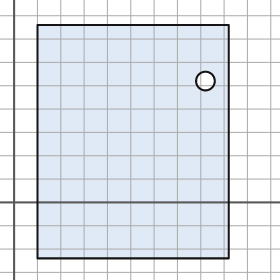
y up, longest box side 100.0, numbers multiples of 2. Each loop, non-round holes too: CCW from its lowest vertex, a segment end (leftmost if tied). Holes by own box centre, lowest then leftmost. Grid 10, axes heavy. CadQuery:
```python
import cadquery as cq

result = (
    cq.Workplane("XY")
    .moveTo(10.0, -24.0)
    .lineTo(92.0, -24.0)
    .lineTo(92.0, 76.0)
    .lineTo(10.0, 76.0)
    .close()
    .moveTo(82.0, 52.0)
    .circle(4.0)
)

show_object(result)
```